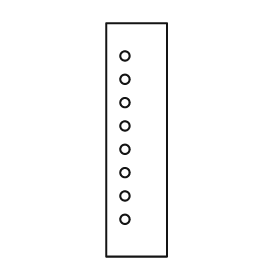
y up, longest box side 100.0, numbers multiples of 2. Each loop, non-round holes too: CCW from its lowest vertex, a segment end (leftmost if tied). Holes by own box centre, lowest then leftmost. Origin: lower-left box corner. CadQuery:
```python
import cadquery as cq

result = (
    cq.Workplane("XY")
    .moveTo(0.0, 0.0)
    .lineTo(26.0, 0.0)
    .lineTo(26.0, 100.0)
    .lineTo(0.0, 100.0)
    .close()
    .moveTo(8.0, 16.0)
    .circle(2.0)
    .moveTo(8.0, 26.0)
    .circle(2.0)
    .moveTo(8.0, 36.0)
    .circle(2.0)
    .moveTo(8.0, 46.0)
    .circle(2.0)
    .moveTo(8.0, 56.0)
    .circle(2.0)
    .moveTo(8.0, 66.0)
    .circle(2.0)
    .moveTo(8.0, 76.0)
    .circle(2.0)
    .moveTo(8.0, 86.0)
    .circle(2.0)
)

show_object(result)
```